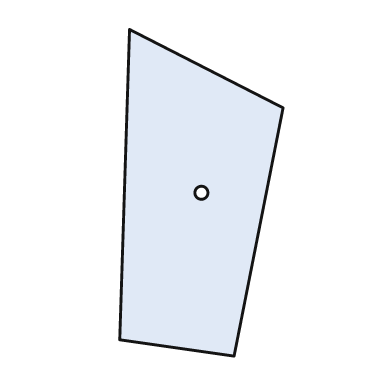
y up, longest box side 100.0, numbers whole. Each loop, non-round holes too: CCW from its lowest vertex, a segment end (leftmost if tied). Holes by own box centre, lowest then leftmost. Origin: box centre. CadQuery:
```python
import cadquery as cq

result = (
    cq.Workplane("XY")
    .moveTo(10.0, -50.0)
    .lineTo(25.0, 26.0)
    .lineTo(-22.0, 50.0)
    .lineTo(-25.0, -45.0)
    .close()
    .moveTo(0.0, 0.0)
    .circle(2.0)
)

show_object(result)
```